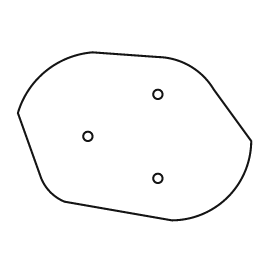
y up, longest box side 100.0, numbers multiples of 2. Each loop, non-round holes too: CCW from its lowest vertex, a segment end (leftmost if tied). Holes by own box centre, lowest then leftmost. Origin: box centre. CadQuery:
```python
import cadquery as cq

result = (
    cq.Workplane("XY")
    .moveTo(16.0, -36.0)
    .threePointArc((40.0, -26.0), (50.0, -2.0))
    .lineTo(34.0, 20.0)
    .threePointArc((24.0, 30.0), (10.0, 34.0))
    .lineTo(-18.0, 36.0)
    .threePointArc((-38.0, 28.0), (-50.0, 10.0))
    .lineTo(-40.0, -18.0)
    .threePointArc((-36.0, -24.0), (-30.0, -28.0))
    .close()
    .moveTo(10.0, -18.0)
    .circle(2.0)
    .moveTo(-20.0, 0.0)
    .circle(2.0)
    .moveTo(10.0, 18.0)
    .circle(2.0)
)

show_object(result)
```